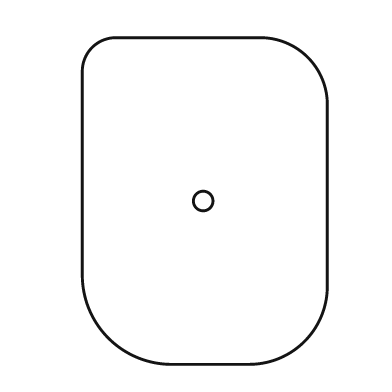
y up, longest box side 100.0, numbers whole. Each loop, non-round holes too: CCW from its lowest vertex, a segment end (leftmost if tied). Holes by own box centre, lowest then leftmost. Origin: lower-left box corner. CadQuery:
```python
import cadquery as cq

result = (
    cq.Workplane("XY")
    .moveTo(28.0, 0.0)
    .lineTo(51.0, 0.0)
    .threePointArc((68.0, 7.0), (75.0, 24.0))
    .lineTo(75.0, 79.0)
    .threePointArc((69.0, 94.0), (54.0, 100.0))
    .lineTo(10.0, 100.0)
    .threePointArc((3.0, 97.0), (0.0, 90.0))
    .lineTo(0.0, 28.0)
    .threePointArc((8.0, 8.0), (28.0, 0.0))
    .close()
    .moveTo(37.0, 50.0)
    .circle(3.0)
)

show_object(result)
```